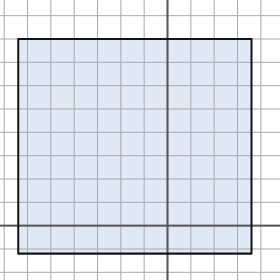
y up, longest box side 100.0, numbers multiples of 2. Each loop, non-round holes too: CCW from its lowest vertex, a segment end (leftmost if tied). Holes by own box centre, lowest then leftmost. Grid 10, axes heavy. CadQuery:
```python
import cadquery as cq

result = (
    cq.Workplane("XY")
    .moveTo(-64.0, -12.0)
    .lineTo(36.0, -12.0)
    .lineTo(36.0, 80.0)
    .lineTo(-64.0, 80.0)
    .close()
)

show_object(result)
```